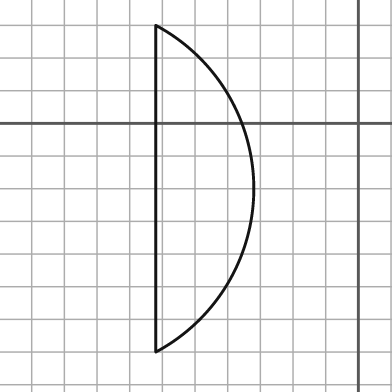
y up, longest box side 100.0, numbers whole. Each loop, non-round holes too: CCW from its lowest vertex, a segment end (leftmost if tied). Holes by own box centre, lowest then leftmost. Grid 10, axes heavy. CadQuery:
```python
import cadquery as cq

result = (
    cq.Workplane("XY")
    .moveTo(-62.0, -70.0)
    .threePointArc((-32.0, -20.0), (-62.0, 30.0))
    .close()
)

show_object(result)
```